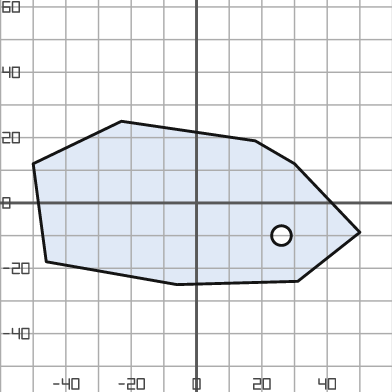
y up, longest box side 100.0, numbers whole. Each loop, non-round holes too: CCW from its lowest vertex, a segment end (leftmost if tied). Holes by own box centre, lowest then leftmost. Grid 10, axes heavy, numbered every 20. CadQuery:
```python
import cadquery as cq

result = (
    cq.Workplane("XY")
    .moveTo(-6.0, -25.0)
    .lineTo(31.0, -24.0)
    .lineTo(50.0, -9.0)
    .lineTo(30.0, 12.0)
    .lineTo(18.0, 19.0)
    .lineTo(-23.0, 25.0)
    .lineTo(-50.0, 12.0)
    .lineTo(-46.0, -18.0)
    .close()
    .moveTo(26.0, -10.0)
    .circle(3.0)
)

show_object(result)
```